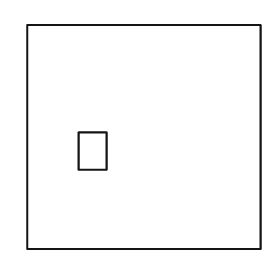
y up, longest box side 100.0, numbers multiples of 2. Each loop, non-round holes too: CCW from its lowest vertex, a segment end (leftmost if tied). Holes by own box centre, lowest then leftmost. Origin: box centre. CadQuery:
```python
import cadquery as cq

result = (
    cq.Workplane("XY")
    .moveTo(-50.0, -48.0)
    .lineTo(50.0, -48.0)
    .lineTo(50.0, 48.0)
    .lineTo(-50.0, 48.0)
    .close()
    .moveTo(-28.0, -14.0)
    .lineTo(-16.0, -14.0)
    .lineTo(-16.0, 2.0)
    .lineTo(-28.0, 2.0)
    .close()
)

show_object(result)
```